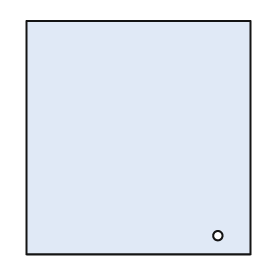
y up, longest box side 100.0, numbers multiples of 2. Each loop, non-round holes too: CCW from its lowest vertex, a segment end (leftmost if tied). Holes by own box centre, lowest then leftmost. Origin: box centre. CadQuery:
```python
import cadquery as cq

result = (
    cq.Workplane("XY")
    .moveTo(-48.0, -50.0)
    .lineTo(48.0, -50.0)
    .lineTo(48.0, 50.0)
    .lineTo(-48.0, 50.0)
    .close()
    .moveTo(34.0, -42.0)
    .circle(2.0)
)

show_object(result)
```